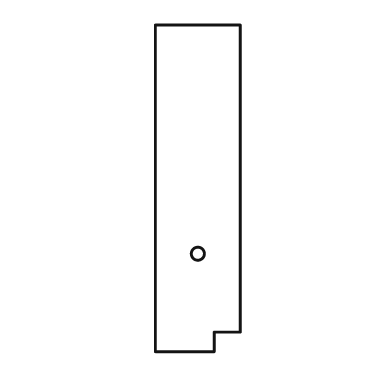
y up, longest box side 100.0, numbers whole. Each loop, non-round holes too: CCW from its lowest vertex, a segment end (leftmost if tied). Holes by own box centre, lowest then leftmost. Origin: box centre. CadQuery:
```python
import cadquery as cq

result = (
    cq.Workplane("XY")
    .moveTo(-13.0, -50.0)
    .lineTo(5.0, -50.0)
    .lineTo(5.0, -44.0)
    .lineTo(13.0, -44.0)
    .lineTo(13.0, 50.0)
    .lineTo(-13.0, 50.0)
    .close()
    .moveTo(0.0, -20.0)
    .circle(2.0)
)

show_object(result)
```